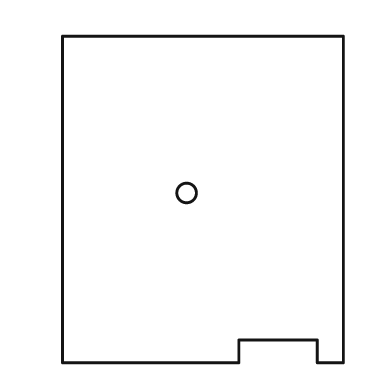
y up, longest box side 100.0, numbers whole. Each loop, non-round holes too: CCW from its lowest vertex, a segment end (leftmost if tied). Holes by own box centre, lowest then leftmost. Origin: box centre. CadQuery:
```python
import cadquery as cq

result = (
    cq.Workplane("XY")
    .moveTo(-43.0, -50.0)
    .lineTo(11.0, -50.0)
    .lineTo(11.0, -43.0)
    .lineTo(35.0, -43.0)
    .lineTo(35.0, -50.0)
    .lineTo(43.0, -50.0)
    .lineTo(43.0, 50.0)
    .lineTo(-43.0, 50.0)
    .close()
    .moveTo(-5.0, 2.0)
    .circle(3.0)
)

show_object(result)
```